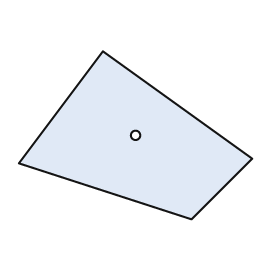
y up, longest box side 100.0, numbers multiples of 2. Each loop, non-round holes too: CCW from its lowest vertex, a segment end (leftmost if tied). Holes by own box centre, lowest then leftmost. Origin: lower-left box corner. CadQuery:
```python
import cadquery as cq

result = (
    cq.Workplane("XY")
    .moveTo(74.0, 0.0)
    .lineTo(100.0, 26.0)
    .lineTo(36.0, 72.0)
    .lineTo(0.0, 24.0)
    .close()
    .moveTo(50.0, 36.0)
    .circle(2.0)
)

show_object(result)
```